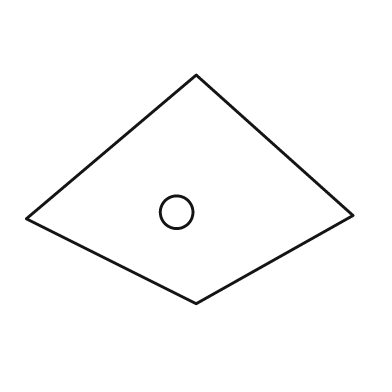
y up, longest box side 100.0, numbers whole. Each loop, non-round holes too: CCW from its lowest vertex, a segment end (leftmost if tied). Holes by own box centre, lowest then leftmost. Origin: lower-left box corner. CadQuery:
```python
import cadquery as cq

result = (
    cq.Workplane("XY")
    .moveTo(52.0, 0.0)
    .lineTo(100.0, 27.0)
    .lineTo(52.0, 70.0)
    .lineTo(0.0, 26.0)
    .close()
    .moveTo(46.0, 28.0)
    .circle(5.0)
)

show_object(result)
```